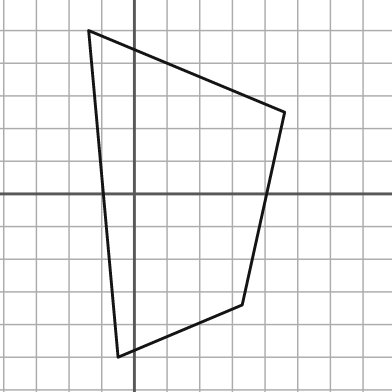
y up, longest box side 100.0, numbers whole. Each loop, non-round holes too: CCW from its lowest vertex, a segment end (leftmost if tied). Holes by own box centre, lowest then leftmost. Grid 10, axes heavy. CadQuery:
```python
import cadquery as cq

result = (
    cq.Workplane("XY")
    .moveTo(-5.0, -50.0)
    .lineTo(33.0, -34.0)
    .lineTo(46.0, 25.0)
    .lineTo(-14.0, 50.0)
    .close()
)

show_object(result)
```